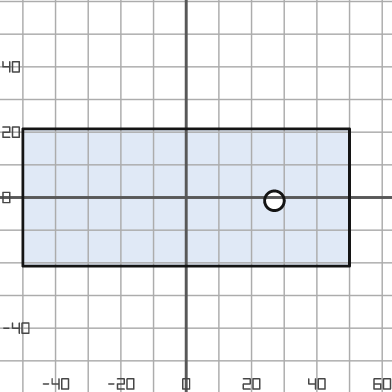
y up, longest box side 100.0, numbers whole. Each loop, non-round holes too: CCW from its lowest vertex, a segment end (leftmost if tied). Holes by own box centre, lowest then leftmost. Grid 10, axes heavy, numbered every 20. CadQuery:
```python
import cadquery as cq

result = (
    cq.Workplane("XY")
    .moveTo(-50.0, -21.0)
    .lineTo(50.0, -21.0)
    .lineTo(50.0, 21.0)
    .lineTo(-50.0, 21.0)
    .close()
    .moveTo(27.0, -1.0)
    .circle(3.0)
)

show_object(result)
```